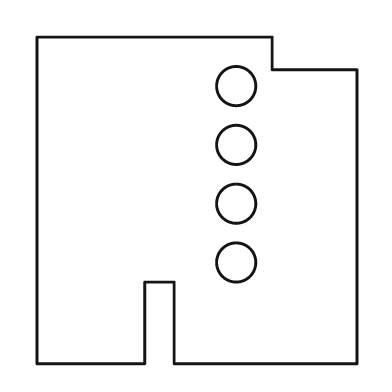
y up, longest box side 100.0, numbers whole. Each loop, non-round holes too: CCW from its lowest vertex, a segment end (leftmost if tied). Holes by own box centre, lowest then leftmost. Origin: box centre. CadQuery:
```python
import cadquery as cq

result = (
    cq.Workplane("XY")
    .moveTo(-49.0, -50.0)
    .lineTo(-16.0, -50.0)
    .lineTo(-16.0, -25.0)
    .lineTo(-7.0, -25.0)
    .lineTo(-7.0, -50.0)
    .lineTo(49.0, -50.0)
    .lineTo(49.0, 40.0)
    .lineTo(23.0, 40.0)
    .lineTo(23.0, 50.0)
    .lineTo(-49.0, 50.0)
    .close()
    .moveTo(12.0, -19.0)
    .circle(6.0)
    .moveTo(12.0, -1.0)
    .circle(6.0)
    .moveTo(12.0, 17.0)
    .circle(6.0)
    .moveTo(12.0, 35.0)
    .circle(6.0)
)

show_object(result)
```